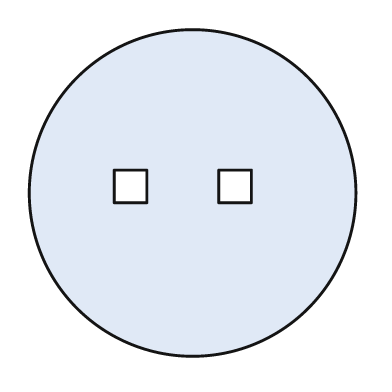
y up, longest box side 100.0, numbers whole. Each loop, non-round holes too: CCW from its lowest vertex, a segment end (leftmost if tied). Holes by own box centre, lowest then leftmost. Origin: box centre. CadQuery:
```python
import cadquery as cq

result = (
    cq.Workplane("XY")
    .moveTo(0.0, 0.0)
    .circle(50.0)
    .moveTo(-24.0, -3.0)
    .lineTo(-14.0, -3.0)
    .lineTo(-14.0, 7.0)
    .lineTo(-24.0, 7.0)
    .close()
    .moveTo(8.0, -3.0)
    .lineTo(18.0, -3.0)
    .lineTo(18.0, 7.0)
    .lineTo(8.0, 7.0)
    .close()
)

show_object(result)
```